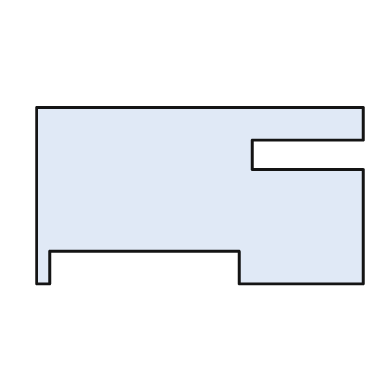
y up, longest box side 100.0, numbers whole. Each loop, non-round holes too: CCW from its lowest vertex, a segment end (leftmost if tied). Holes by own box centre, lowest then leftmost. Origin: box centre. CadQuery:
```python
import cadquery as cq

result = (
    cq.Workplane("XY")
    .moveTo(-50.0, -27.0)
    .lineTo(-46.0, -27.0)
    .lineTo(-46.0, -17.0)
    .lineTo(12.0, -17.0)
    .lineTo(12.0, -27.0)
    .lineTo(50.0, -27.0)
    .lineTo(50.0, 8.0)
    .lineTo(16.0, 8.0)
    .lineTo(16.0, 17.0)
    .lineTo(50.0, 17.0)
    .lineTo(50.0, 27.0)
    .lineTo(-50.0, 27.0)
    .close()
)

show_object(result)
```